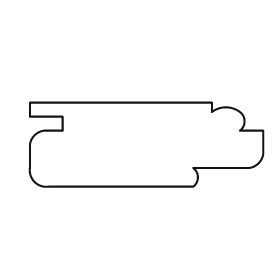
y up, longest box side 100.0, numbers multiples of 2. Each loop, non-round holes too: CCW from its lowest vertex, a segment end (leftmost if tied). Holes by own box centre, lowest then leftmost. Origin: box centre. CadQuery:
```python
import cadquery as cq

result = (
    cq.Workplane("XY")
    .moveTo(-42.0, -18.0)
    .lineTo(20.0, -18.0)
    .threePointArc((22.0, -14.0), (20.0, -10.0))
    .lineTo(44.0, -10.0)
    .threePointArc((48.0, -8.0), (50.0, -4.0))
    .lineTo(50.0, 6.0)
    .lineTo(40.0, 6.0)
    .threePointArc((42.0, 10.0), (40.0, 14.0))
    .threePointArc((34.0, 16.0), (28.0, 14.0))
    .lineTo(28.0, 18.0)
    .lineTo(-50.0, 18.0)
    .lineTo(-50.0, 12.0)
    .lineTo(-36.0, 12.0)
    .lineTo(-36.0, 6.0)
    .lineTo(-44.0, 6.0)
    .threePointArc((-48.0, 4.0), (-50.0, 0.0))
    .lineTo(-50.0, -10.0)
    .threePointArc((-48.0, -16.0), (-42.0, -18.0))
    .close()
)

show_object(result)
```